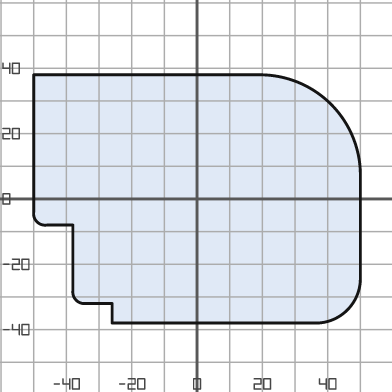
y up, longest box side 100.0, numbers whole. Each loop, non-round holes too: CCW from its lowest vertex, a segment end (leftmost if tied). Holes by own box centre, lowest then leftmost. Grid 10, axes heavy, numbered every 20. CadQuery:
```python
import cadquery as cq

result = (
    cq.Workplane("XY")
    .moveTo(-26.0, -38.0)
    .lineTo(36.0, -38.0)
    .threePointArc((46.0, -34.0), (50.0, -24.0))
    .lineTo(50.0, 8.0)
    .threePointArc((41.0, 29.0), (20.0, 38.0))
    .lineTo(-50.0, 38.0)
    .lineTo(-50.0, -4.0)
    .threePointArc((-49.0, -7.0), (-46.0, -8.0))
    .lineTo(-38.0, -8.0)
    .lineTo(-38.0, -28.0)
    .threePointArc((-37.0, -31.0), (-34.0, -32.0))
    .lineTo(-26.0, -32.0)
    .close()
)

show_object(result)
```